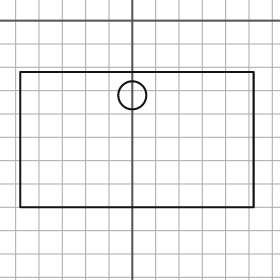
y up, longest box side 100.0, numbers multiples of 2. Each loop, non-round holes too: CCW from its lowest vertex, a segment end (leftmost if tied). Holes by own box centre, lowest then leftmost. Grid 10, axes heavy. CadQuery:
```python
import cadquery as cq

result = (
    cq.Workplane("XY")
    .moveTo(-48.0, -80.0)
    .lineTo(52.0, -80.0)
    .lineTo(52.0, -22.0)
    .lineTo(-48.0, -22.0)
    .close()
    .moveTo(0.0, -32.0)
    .circle(6.0)
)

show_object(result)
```